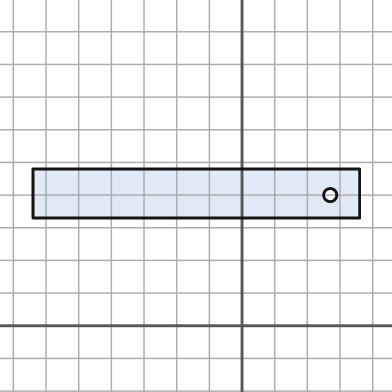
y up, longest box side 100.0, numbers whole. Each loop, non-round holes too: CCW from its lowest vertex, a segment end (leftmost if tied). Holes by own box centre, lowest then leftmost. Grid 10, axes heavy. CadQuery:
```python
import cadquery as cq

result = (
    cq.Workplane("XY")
    .moveTo(-64.0, 33.0)
    .lineTo(36.0, 33.0)
    .lineTo(36.0, 48.0)
    .lineTo(-64.0, 48.0)
    .close()
    .moveTo(27.0, 40.0)
    .circle(2.0)
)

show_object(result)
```